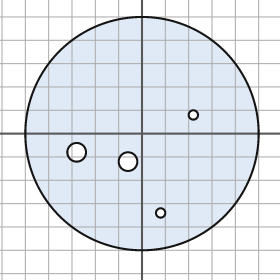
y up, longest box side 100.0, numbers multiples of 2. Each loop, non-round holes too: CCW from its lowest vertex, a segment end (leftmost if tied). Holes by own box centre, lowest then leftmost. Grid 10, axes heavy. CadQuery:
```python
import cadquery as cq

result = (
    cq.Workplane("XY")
    .moveTo(0.0, 0.0)
    .circle(50.0)
    .moveTo(8.0, -34.0)
    .circle(2.0)
    .moveTo(-6.0, -12.0)
    .circle(4.0)
    .moveTo(-28.0, -8.0)
    .circle(4.0)
    .moveTo(22.0, 8.0)
    .circle(2.0)
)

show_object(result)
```